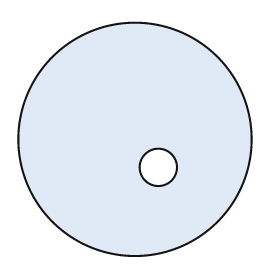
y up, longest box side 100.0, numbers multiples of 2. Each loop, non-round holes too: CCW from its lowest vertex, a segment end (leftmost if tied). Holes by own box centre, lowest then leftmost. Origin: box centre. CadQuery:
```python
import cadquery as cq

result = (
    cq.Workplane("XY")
    .moveTo(0.0, 0.0)
    .circle(50.0)
    .moveTo(10.0, -12.0)
    .circle(8.0)
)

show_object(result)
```